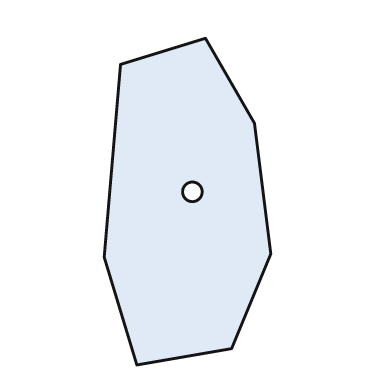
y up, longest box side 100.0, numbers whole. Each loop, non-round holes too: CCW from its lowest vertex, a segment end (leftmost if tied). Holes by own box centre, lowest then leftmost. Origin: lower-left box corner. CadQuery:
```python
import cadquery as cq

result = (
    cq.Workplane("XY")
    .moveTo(10.0, 0.0)
    .lineTo(39.0, 5.0)
    .lineTo(51.0, 34.0)
    .lineTo(46.0, 74.0)
    .lineTo(31.0, 100.0)
    .lineTo(5.0, 92.0)
    .lineTo(0.0, 33.0)
    .close()
    .moveTo(27.0, 53.0)
    .circle(3.0)
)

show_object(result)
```